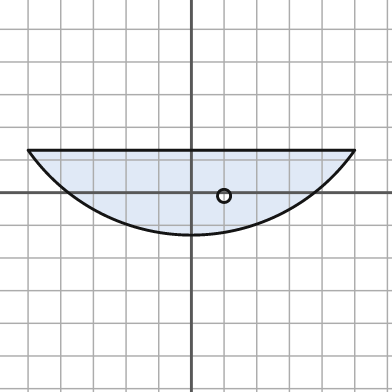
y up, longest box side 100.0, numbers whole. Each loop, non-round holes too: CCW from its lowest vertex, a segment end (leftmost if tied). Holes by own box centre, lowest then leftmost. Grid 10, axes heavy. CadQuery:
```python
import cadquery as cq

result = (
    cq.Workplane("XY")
    .moveTo(-50.0, 13.0)
    .threePointArc((0.0, -13.0), (50.0, 13.0))
    .close()
    .moveTo(10.0, -1.0)
    .circle(2.0)
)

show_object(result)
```